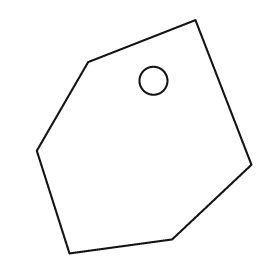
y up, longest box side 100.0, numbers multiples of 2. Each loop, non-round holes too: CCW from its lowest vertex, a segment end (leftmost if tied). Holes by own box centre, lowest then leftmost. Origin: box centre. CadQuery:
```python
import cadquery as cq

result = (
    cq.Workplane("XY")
    .moveTo(-32.0, -50.0)
    .lineTo(12.0, -44.0)
    .lineTo(46.0, -12.0)
    .lineTo(22.0, 50.0)
    .lineTo(-24.0, 32.0)
    .lineTo(-46.0, -6.0)
    .close()
    .moveTo(4.0, 24.0)
    .circle(6.0)
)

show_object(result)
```